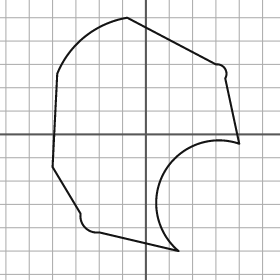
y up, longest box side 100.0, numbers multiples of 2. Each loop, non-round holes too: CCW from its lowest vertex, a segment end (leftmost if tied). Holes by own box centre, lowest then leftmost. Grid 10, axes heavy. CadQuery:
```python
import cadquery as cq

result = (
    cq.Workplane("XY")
    .moveTo(14.0, -50.0)
    .threePointArc((8.0, -16.0), (40.0, -4.0))
    .lineTo(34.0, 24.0)
    .threePointArc((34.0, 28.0), (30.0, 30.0))
    .lineTo(-8.0, 50.0)
    .threePointArc((-26.0, 42.0), (-38.0, 26.0))
    .lineTo(-40.0, -14.0)
    .lineTo(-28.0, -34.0)
    .threePointArc((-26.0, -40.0), (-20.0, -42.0))
    .close()
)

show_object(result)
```